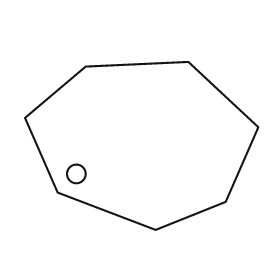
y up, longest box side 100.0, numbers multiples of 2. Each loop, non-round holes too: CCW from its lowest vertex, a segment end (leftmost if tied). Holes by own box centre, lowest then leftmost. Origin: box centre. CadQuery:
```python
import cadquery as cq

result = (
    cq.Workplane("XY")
    .moveTo(6.0, -36.0)
    .lineTo(36.0, -24.0)
    .lineTo(50.0, 8.0)
    .lineTo(20.0, 36.0)
    .lineTo(-24.0, 34.0)
    .lineTo(-50.0, 12.0)
    .lineTo(-36.0, -20.0)
    .close()
    .moveTo(-28.0, -12.0)
    .circle(4.0)
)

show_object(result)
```